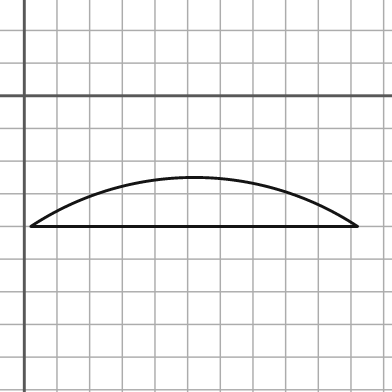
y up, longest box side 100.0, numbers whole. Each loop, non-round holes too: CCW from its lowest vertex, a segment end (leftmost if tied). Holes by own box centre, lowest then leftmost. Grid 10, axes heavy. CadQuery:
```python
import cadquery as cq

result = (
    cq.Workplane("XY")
    .moveTo(2.0, -40.0)
    .lineTo(102.0, -40.0)
    .threePointArc((52.0, -25.0), (2.0, -40.0))
    .close()
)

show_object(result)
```